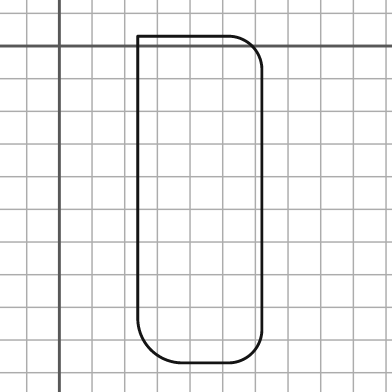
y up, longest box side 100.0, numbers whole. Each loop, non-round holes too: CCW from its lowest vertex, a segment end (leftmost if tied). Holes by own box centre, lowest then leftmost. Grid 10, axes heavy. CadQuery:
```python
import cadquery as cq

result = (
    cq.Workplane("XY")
    .moveTo(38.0, -97.0)
    .lineTo(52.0, -97.0)
    .threePointArc((59.0, -94.0), (62.0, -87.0))
    .lineTo(62.0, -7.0)
    .threePointArc((59.0, 0.0), (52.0, 3.0))
    .lineTo(24.0, 3.0)
    .lineTo(24.0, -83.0)
    .threePointArc((28.0, -93.0), (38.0, -97.0))
    .close()
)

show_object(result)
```